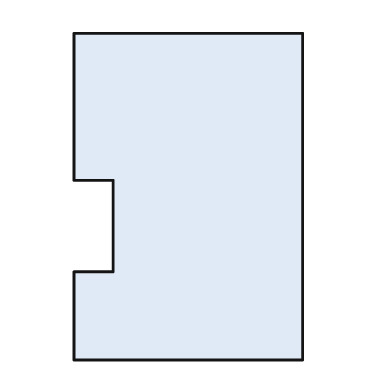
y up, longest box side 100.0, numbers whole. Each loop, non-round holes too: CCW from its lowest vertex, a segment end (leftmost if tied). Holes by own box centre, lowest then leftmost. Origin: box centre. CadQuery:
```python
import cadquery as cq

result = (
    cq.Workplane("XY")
    .moveTo(-35.0, -50.0)
    .lineTo(35.0, -50.0)
    .lineTo(35.0, 50.0)
    .lineTo(-35.0, 50.0)
    .lineTo(-35.0, 5.0)
    .lineTo(-23.0, 5.0)
    .lineTo(-23.0, -23.0)
    .lineTo(-35.0, -23.0)
    .close()
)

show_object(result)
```